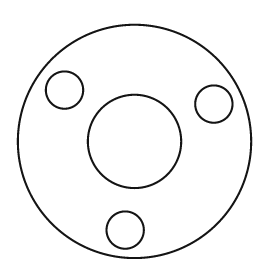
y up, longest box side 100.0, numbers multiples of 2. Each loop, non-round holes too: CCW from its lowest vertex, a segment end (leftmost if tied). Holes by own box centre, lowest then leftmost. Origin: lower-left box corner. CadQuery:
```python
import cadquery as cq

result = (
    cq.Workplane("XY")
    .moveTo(50.0, 50.0)
    .circle(50.0)
    .moveTo(46.0, 12.0)
    .circle(8.0)
    .moveTo(50.0, 50.0)
    .circle(20.0)
    .moveTo(84.0, 66.0)
    .circle(8.0)
    .moveTo(20.0, 72.0)
    .circle(8.0)
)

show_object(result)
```